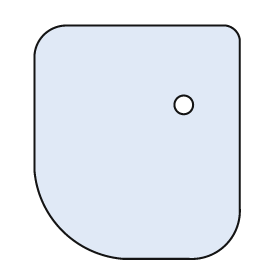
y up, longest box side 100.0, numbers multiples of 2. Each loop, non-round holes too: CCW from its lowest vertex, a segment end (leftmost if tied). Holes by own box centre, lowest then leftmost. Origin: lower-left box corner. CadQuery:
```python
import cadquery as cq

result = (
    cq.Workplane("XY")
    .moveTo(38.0, 0.0)
    .lineTo(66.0, 0.0)
    .threePointArc((82.0, 6.0), (88.0, 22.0))
    .lineTo(88.0, 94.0)
    .threePointArc((86.0, 98.0), (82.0, 100.0))
    .lineTo(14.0, 100.0)
    .threePointArc((4.0, 96.0), (0.0, 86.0))
    .lineTo(0.0, 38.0)
    .threePointArc((12.0, 12.0), (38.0, 0.0))
    .close()
    .moveTo(64.0, 66.0)
    .circle(4.0)
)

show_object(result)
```